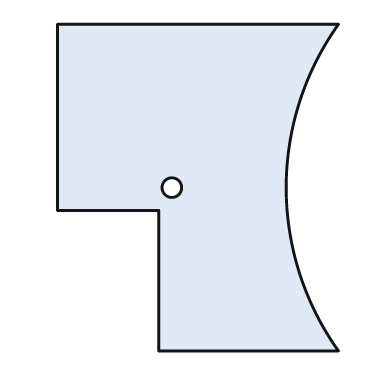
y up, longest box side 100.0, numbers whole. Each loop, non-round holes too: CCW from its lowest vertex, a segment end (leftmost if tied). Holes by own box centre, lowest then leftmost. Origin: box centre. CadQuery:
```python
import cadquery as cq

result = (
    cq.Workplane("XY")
    .moveTo(-12.0, -50.0)
    .lineTo(43.0, -50.0)
    .threePointArc((27.0, 0.0), (43.0, 50.0))
    .lineTo(-43.0, 50.0)
    .lineTo(-43.0, -7.0)
    .lineTo(-12.0, -7.0)
    .close()
    .moveTo(-8.0, 0.0)
    .circle(3.0)
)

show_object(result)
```